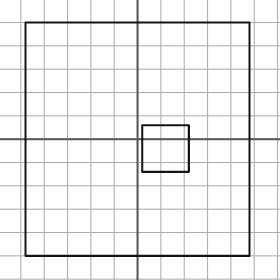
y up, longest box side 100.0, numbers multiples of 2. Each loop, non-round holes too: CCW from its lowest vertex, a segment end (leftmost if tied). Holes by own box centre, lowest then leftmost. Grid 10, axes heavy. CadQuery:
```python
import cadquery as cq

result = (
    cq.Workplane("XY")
    .moveTo(-48.0, -50.0)
    .lineTo(48.0, -50.0)
    .lineTo(48.0, 50.0)
    .lineTo(-48.0, 50.0)
    .close()
    .moveTo(2.0, -14.0)
    .lineTo(22.0, -14.0)
    .lineTo(22.0, 6.0)
    .lineTo(2.0, 6.0)
    .close()
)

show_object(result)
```